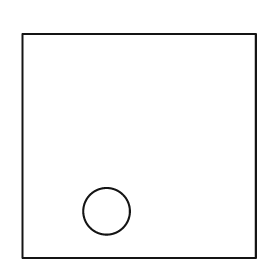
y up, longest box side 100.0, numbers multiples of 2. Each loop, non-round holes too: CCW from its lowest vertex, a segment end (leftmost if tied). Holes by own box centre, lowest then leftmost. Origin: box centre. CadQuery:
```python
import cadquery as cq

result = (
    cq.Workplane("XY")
    .moveTo(-50.0, -48.0)
    .lineTo(50.0, -48.0)
    .lineTo(50.0, 48.0)
    .lineTo(-50.0, 48.0)
    .close()
    .moveTo(-14.0, -28.0)
    .circle(10.0)
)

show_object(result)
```